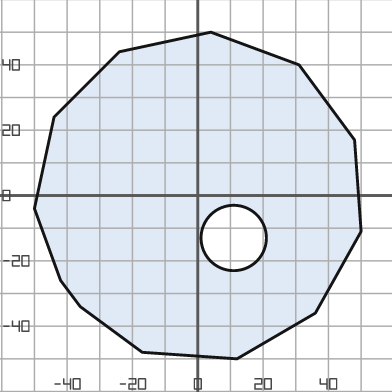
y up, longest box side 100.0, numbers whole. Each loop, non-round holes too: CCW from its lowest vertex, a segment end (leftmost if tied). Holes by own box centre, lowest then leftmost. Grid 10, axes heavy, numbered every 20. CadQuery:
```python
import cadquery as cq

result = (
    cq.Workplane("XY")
    .moveTo(12.0, -50.0)
    .lineTo(36.0, -36.0)
    .lineTo(50.0, -11.0)
    .lineTo(48.0, 17.0)
    .lineTo(31.0, 40.0)
    .lineTo(4.0, 50.0)
    .lineTo(-24.0, 44.0)
    .lineTo(-44.0, 24.0)
    .lineTo(-50.0, -4.0)
    .lineTo(-42.0, -26.0)
    .lineTo(-36.0, -34.0)
    .lineTo(-17.0, -48.0)
    .close()
    .moveTo(11.0, -13.0)
    .circle(10.0)
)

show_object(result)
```